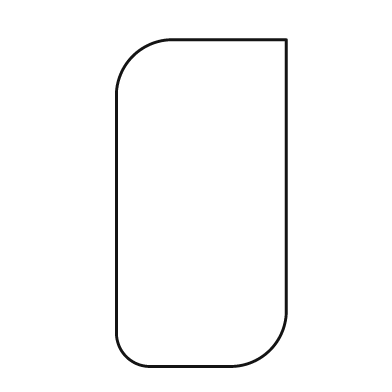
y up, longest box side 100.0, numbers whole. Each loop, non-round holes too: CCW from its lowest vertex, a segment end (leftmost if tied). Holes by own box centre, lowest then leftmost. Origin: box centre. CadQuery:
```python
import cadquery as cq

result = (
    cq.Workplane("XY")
    .moveTo(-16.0, -50.0)
    .lineTo(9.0, -50.0)
    .threePointArc((21.0, -45.0), (26.0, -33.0))
    .lineTo(26.0, 50.0)
    .lineTo(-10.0, 50.0)
    .threePointArc((-21.0, 45.0), (-26.0, 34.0))
    .lineTo(-26.0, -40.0)
    .threePointArc((-23.0, -47.0), (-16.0, -50.0))
    .close()
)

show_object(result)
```